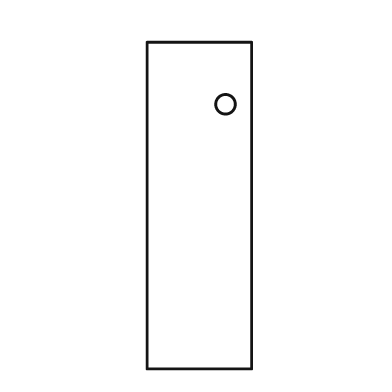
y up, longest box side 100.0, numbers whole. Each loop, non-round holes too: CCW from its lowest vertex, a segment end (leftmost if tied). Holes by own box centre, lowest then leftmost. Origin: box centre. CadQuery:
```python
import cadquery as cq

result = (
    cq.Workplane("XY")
    .moveTo(-16.0, -50.0)
    .lineTo(16.0, -50.0)
    .lineTo(16.0, 50.0)
    .lineTo(-16.0, 50.0)
    .close()
    .moveTo(8.0, 31.0)
    .circle(3.0)
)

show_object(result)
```